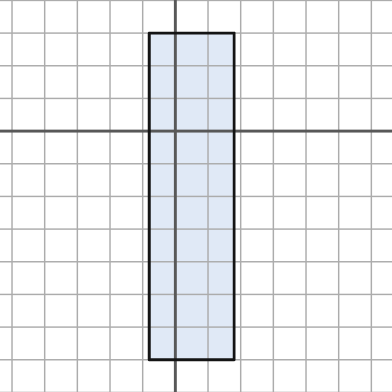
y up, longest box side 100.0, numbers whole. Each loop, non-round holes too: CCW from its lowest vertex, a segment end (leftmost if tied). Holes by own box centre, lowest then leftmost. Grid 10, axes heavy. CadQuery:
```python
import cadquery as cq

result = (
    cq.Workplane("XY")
    .moveTo(-8.0, -70.0)
    .lineTo(18.0, -70.0)
    .lineTo(18.0, 30.0)
    .lineTo(-8.0, 30.0)
    .close()
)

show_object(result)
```